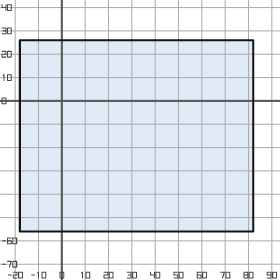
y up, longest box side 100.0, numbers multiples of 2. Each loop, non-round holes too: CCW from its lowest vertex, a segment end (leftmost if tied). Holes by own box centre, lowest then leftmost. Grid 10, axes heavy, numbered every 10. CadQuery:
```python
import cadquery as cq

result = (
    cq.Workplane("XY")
    .moveTo(-18.0, -56.0)
    .lineTo(82.0, -56.0)
    .lineTo(82.0, 26.0)
    .lineTo(-18.0, 26.0)
    .close()
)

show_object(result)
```